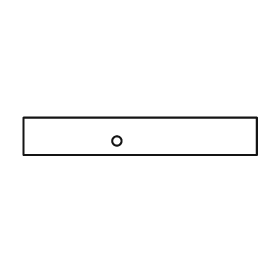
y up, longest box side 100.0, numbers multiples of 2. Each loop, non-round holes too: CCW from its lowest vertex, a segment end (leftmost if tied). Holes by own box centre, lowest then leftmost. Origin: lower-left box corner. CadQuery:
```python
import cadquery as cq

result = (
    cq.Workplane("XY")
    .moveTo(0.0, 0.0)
    .lineTo(100.0, 0.0)
    .lineTo(100.0, 16.0)
    .lineTo(0.0, 16.0)
    .close()
    .moveTo(40.0, 6.0)
    .circle(2.0)
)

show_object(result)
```